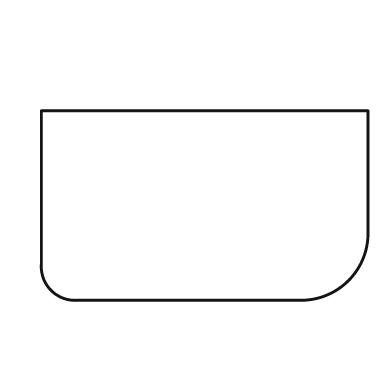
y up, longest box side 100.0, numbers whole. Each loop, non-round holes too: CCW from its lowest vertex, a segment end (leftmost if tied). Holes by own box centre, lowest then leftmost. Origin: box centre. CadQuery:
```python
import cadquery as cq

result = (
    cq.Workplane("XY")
    .moveTo(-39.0, -29.0)
    .lineTo(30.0, -29.0)
    .threePointArc((44.0, -23.0), (50.0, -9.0))
    .lineTo(50.0, 29.0)
    .lineTo(-50.0, 29.0)
    .lineTo(-50.0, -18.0)
    .threePointArc((-47.0, -26.0), (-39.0, -29.0))
    .close()
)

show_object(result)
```